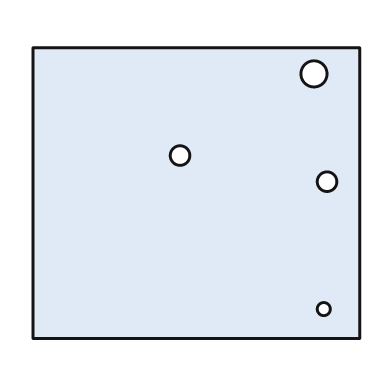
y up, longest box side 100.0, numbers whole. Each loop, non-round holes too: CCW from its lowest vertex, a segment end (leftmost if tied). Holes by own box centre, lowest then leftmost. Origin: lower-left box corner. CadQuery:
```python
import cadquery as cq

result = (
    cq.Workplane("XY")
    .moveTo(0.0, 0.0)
    .lineTo(100.0, 0.0)
    .lineTo(100.0, 89.0)
    .lineTo(0.0, 89.0)
    .close()
    .moveTo(89.0, 9.0)
    .circle(2.0)
    .moveTo(90.0, 48.0)
    .circle(3.0)
    .moveTo(45.0, 56.0)
    .circle(3.0)
    .moveTo(86.0, 81.0)
    .circle(4.0)
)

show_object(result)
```